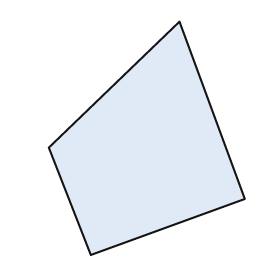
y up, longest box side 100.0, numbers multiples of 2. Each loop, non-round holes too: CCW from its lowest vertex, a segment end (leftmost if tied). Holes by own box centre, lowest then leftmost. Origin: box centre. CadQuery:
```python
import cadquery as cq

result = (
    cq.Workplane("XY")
    .moveTo(-24.0, -50.0)
    .lineTo(42.0, -26.0)
    .lineTo(14.0, 50.0)
    .lineTo(-42.0, -4.0)
    .close()
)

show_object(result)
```